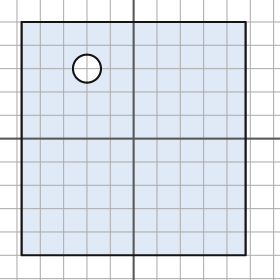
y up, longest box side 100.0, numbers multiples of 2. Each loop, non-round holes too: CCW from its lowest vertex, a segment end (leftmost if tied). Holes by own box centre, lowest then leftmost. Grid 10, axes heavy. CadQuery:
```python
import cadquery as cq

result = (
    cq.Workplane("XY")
    .moveTo(-48.0, -50.0)
    .lineTo(48.0, -50.0)
    .lineTo(48.0, 50.0)
    .lineTo(-48.0, 50.0)
    .close()
    .moveTo(-20.0, 30.0)
    .circle(6.0)
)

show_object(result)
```